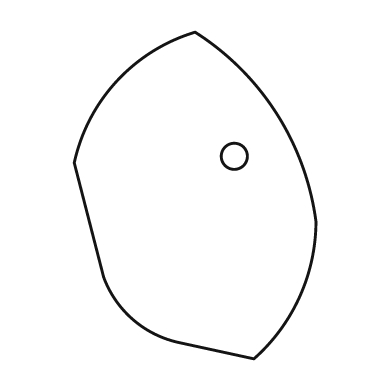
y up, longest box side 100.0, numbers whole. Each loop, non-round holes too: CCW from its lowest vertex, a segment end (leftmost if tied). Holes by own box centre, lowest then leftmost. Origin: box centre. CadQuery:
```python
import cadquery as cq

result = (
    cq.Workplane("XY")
    .moveTo(18.0, -50.0)
    .threePointArc((32.0, -31.0), (37.0, -8.0))
    .threePointArc((25.0, 25.0), (0.0, 50.0))
    .threePointArc((-24.0, 35.0), (-37.0, 10.0))
    .lineTo(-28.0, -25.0)
    .threePointArc((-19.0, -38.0), (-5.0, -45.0))
    .close()
    .moveTo(12.0, 12.0)
    .circle(4.0)
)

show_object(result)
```